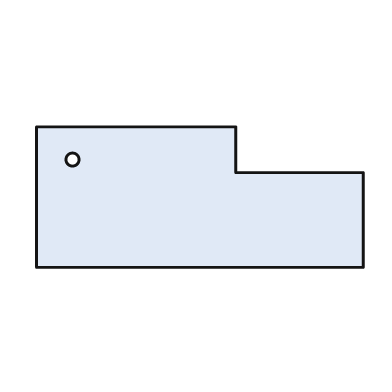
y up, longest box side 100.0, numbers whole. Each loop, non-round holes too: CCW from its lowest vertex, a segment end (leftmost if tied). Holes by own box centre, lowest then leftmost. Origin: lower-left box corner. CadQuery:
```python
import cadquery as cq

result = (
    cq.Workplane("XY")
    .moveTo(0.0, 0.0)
    .lineTo(100.0, 0.0)
    .lineTo(100.0, 29.0)
    .lineTo(61.0, 29.0)
    .lineTo(61.0, 43.0)
    .lineTo(0.0, 43.0)
    .close()
    .moveTo(11.0, 33.0)
    .circle(2.0)
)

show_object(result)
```